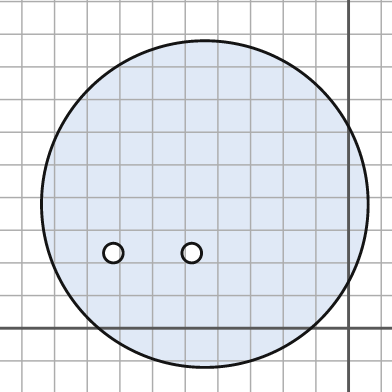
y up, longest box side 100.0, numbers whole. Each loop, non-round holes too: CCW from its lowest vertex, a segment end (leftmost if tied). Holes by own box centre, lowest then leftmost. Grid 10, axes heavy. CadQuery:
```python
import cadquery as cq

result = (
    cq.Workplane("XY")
    .moveTo(-44.0, 38.0)
    .circle(50.0)
    .moveTo(-72.0, 23.0)
    .circle(3.0)
    .moveTo(-48.0, 23.0)
    .circle(3.0)
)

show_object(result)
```